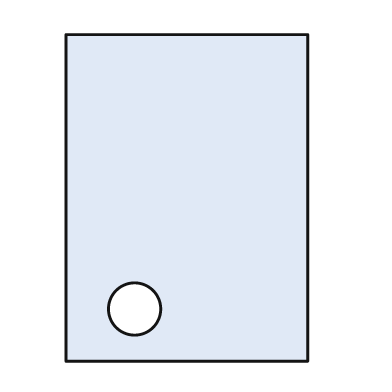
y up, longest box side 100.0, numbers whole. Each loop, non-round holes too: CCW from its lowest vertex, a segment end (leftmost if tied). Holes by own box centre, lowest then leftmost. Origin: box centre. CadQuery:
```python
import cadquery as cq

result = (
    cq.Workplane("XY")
    .moveTo(-37.0, -50.0)
    .lineTo(37.0, -50.0)
    .lineTo(37.0, 50.0)
    .lineTo(-37.0, 50.0)
    .close()
    .moveTo(-16.0, -34.0)
    .circle(8.0)
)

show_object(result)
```